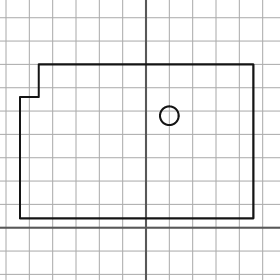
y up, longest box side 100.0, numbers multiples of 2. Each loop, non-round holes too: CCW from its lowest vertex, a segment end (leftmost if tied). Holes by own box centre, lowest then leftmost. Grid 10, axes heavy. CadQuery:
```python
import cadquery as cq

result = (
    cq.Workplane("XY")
    .moveTo(-54.0, 4.0)
    .lineTo(46.0, 4.0)
    .lineTo(46.0, 70.0)
    .lineTo(-46.0, 70.0)
    .lineTo(-46.0, 56.0)
    .lineTo(-54.0, 56.0)
    .close()
    .moveTo(10.0, 48.0)
    .circle(4.0)
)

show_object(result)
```